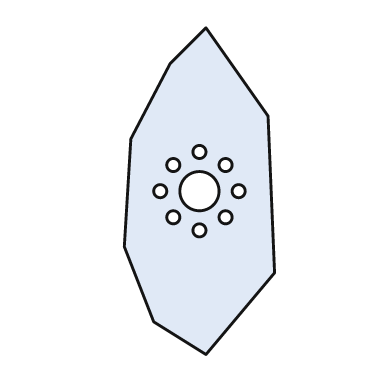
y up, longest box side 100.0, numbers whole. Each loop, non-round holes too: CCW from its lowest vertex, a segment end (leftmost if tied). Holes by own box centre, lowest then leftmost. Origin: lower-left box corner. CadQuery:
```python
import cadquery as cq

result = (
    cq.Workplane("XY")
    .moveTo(25.0, 0.0)
    .lineTo(46.0, 25.0)
    .lineTo(44.0, 73.0)
    .lineTo(25.0, 100.0)
    .lineTo(14.0, 89.0)
    .lineTo(2.0, 66.0)
    .lineTo(0.0, 33.0)
    .lineTo(9.0, 10.0)
    .close()
    .moveTo(23.0, 38.0)
    .circle(2.0)
    .moveTo(15.0, 42.0)
    .circle(2.0)
    .moveTo(31.0, 42.0)
    .circle(2.0)
    .moveTo(11.0, 50.0)
    .circle(2.0)
    .moveTo(23.0, 50.0)
    .circle(6.0)
    .moveTo(35.0, 50.0)
    .circle(2.0)
    .moveTo(15.0, 58.0)
    .circle(2.0)
    .moveTo(31.0, 58.0)
    .circle(2.0)
    .moveTo(23.0, 62.0)
    .circle(2.0)
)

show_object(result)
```